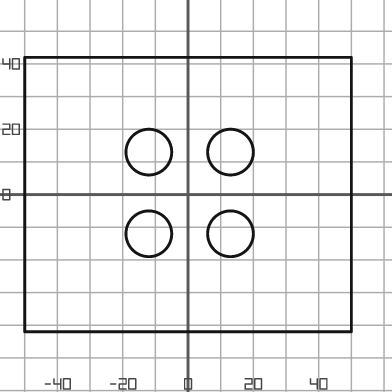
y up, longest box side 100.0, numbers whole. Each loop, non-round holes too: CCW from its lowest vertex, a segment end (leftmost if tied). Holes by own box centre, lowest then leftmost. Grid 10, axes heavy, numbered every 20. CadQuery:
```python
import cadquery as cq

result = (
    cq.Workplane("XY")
    .moveTo(-50.0, -42.0)
    .lineTo(50.0, -42.0)
    .lineTo(50.0, 42.0)
    .lineTo(-50.0, 42.0)
    .close()
    .moveTo(-12.0, -12.0)
    .circle(7.0)
    .moveTo(13.0, -12.0)
    .circle(7.0)
    .moveTo(-12.0, 13.0)
    .circle(7.0)
    .moveTo(13.0, 13.0)
    .circle(7.0)
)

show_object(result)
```